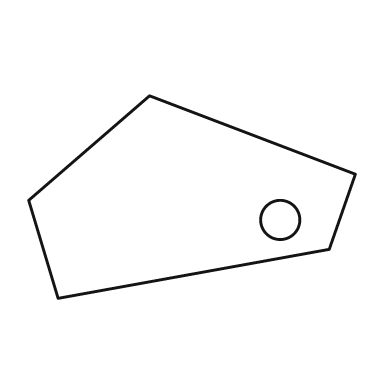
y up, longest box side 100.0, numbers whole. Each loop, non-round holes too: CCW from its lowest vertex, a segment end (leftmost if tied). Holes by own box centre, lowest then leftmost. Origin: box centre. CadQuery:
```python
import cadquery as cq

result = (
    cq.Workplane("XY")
    .moveTo(-41.0, -31.0)
    .lineTo(42.0, -16.0)
    .lineTo(50.0, 7.0)
    .lineTo(-13.0, 31.0)
    .lineTo(-50.0, -1.0)
    .close()
    .moveTo(27.0, -7.0)
    .circle(6.0)
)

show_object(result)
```